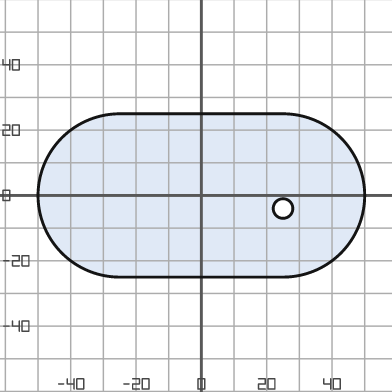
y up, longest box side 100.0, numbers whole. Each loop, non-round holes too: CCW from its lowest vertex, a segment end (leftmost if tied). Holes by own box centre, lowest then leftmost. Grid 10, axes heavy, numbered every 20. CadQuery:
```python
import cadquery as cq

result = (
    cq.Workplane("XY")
    .moveTo(-25.0, -25.0)
    .lineTo(25.0, -25.0)
    .threePointArc((50.0, 0.0), (25.0, 25.0))
    .lineTo(-25.0, 25.0)
    .threePointArc((-50.0, 0.0), (-25.0, -25.0))
    .close()
    .moveTo(25.0, -4.0)
    .circle(3.0)
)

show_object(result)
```